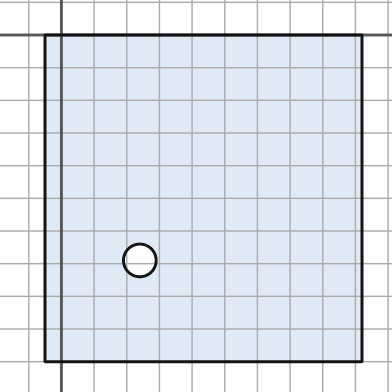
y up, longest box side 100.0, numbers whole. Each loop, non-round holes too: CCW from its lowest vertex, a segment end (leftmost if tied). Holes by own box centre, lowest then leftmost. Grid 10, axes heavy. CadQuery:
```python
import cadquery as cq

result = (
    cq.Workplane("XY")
    .moveTo(-5.0, -100.0)
    .lineTo(92.0, -100.0)
    .lineTo(92.0, 0.0)
    .lineTo(-5.0, 0.0)
    .close()
    .moveTo(24.0, -69.0)
    .circle(5.0)
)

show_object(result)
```